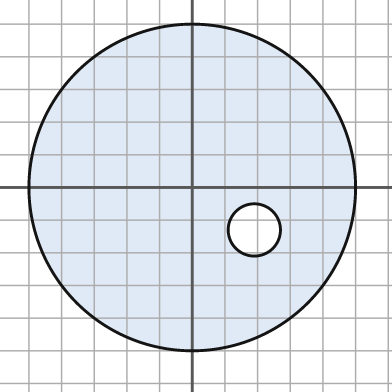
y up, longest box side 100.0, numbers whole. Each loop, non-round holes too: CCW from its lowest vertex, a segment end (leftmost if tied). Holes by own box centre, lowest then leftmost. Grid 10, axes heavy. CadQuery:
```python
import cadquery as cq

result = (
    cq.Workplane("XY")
    .moveTo(0.0, 0.0)
    .circle(50.0)
    .moveTo(19.0, -13.0)
    .circle(8.0)
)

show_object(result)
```